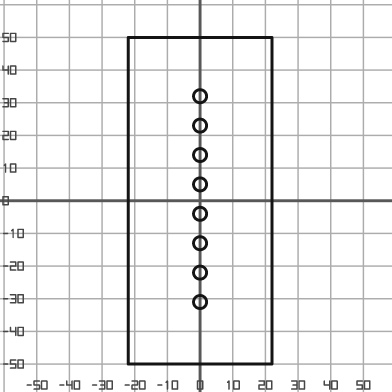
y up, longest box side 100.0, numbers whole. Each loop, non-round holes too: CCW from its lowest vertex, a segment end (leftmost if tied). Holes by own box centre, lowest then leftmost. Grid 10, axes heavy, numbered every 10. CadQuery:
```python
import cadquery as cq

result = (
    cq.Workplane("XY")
    .moveTo(-22.0, -50.0)
    .lineTo(22.0, -50.0)
    .lineTo(22.0, 50.0)
    .lineTo(-22.0, 50.0)
    .close()
    .moveTo(0.0, -31.0)
    .circle(2.0)
    .moveTo(0.0, -22.0)
    .circle(2.0)
    .moveTo(0.0, -13.0)
    .circle(2.0)
    .moveTo(0.0, -4.0)
    .circle(2.0)
    .moveTo(0.0, 5.0)
    .circle(2.0)
    .moveTo(0.0, 14.0)
    .circle(2.0)
    .moveTo(0.0, 23.0)
    .circle(2.0)
    .moveTo(0.0, 32.0)
    .circle(2.0)
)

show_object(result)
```